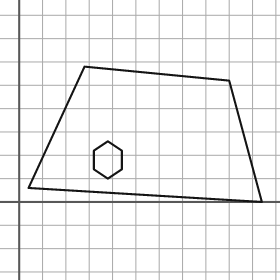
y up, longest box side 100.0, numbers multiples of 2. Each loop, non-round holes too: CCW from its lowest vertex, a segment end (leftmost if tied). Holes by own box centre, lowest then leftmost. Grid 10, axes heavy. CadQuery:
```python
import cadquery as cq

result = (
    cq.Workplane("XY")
    .moveTo(104.0, 0.0)
    .lineTo(90.0, 52.0)
    .lineTo(28.0, 58.0)
    .lineTo(4.0, 6.0)
    .close()
    .moveTo(38.0, 10.0)
    .lineTo(44.0, 14.0)
    .lineTo(44.0, 22.0)
    .lineTo(38.0, 26.0)
    .lineTo(32.0, 22.0)
    .lineTo(32.0, 14.0)
    .close()
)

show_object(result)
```